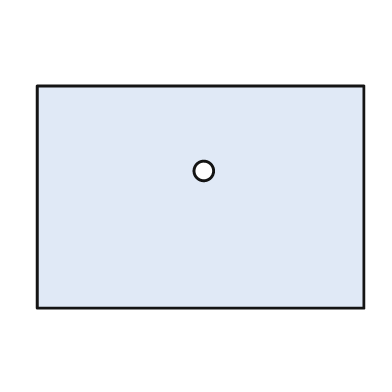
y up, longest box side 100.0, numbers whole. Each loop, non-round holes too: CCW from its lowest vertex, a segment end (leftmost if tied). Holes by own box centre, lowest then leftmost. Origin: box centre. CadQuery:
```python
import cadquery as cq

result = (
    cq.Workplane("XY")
    .moveTo(-50.0, -34.0)
    .lineTo(50.0, -34.0)
    .lineTo(50.0, 34.0)
    .lineTo(-50.0, 34.0)
    .close()
    .moveTo(1.0, 8.0)
    .circle(3.0)
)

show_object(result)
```